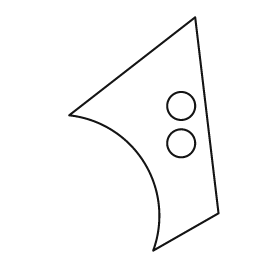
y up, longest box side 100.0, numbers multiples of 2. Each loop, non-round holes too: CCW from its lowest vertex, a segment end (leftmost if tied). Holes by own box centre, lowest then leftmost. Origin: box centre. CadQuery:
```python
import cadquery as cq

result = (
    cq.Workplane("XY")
    .moveTo(4.0, -50.0)
    .lineTo(32.0, -34.0)
    .lineTo(22.0, 50.0)
    .lineTo(-32.0, 8.0)
    .threePointArc((0.0, -12.0), (4.0, -50.0))
    .close()
    .moveTo(16.0, -4.0)
    .circle(6.0)
    .moveTo(16.0, 12.0)
    .circle(6.0)
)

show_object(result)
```